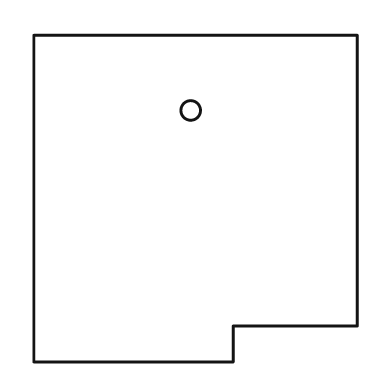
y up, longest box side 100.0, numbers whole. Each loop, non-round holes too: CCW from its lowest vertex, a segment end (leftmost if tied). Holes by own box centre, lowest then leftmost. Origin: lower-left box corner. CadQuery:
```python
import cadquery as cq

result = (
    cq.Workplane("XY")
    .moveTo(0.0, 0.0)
    .lineTo(61.0, 0.0)
    .lineTo(61.0, 11.0)
    .lineTo(99.0, 11.0)
    .lineTo(99.0, 100.0)
    .lineTo(0.0, 100.0)
    .close()
    .moveTo(48.0, 77.0)
    .circle(3.0)
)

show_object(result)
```